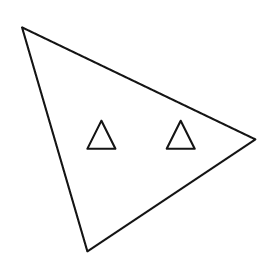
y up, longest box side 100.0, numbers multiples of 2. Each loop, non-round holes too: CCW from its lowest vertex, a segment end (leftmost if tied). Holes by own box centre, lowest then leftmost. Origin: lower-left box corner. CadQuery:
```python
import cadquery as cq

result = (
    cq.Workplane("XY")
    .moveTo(28.0, 0.0)
    .lineTo(100.0, 48.0)
    .lineTo(0.0, 96.0)
    .close()
    .moveTo(28.0, 44.0)
    .lineTo(40.0, 44.0)
    .lineTo(34.0, 56.0)
    .close()
    .moveTo(62.0, 44.0)
    .lineTo(74.0, 44.0)
    .lineTo(68.0, 56.0)
    .close()
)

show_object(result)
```